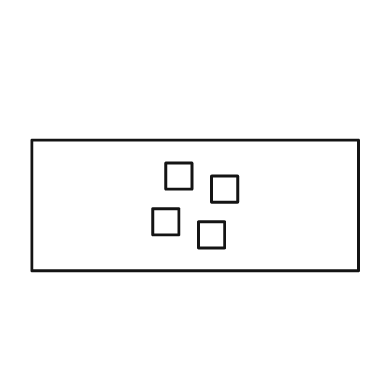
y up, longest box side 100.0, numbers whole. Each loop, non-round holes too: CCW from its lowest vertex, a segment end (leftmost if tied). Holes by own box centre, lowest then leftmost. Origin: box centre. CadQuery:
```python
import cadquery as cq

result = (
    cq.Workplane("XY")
    .moveTo(-50.0, -20.0)
    .lineTo(50.0, -20.0)
    .lineTo(50.0, 20.0)
    .lineTo(-50.0, 20.0)
    .close()
    .moveTo(1.0, -13.0)
    .lineTo(9.0, -13.0)
    .lineTo(9.0, -5.0)
    .lineTo(1.0, -5.0)
    .close()
    .moveTo(-13.0, -9.0)
    .lineTo(-5.0, -9.0)
    .lineTo(-5.0, -1.0)
    .lineTo(-13.0, -1.0)
    .close()
    .moveTo(5.0, 1.0)
    .lineTo(13.0, 1.0)
    .lineTo(13.0, 9.0)
    .lineTo(5.0, 9.0)
    .close()
    .moveTo(-9.0, 5.0)
    .lineTo(-1.0, 5.0)
    .lineTo(-1.0, 13.0)
    .lineTo(-9.0, 13.0)
    .close()
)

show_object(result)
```